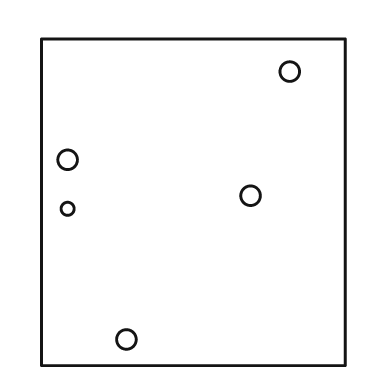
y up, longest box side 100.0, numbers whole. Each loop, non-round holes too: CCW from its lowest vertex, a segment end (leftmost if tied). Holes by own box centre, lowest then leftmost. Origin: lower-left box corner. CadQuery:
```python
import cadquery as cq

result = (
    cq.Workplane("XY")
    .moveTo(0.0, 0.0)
    .lineTo(93.0, 0.0)
    .lineTo(93.0, 100.0)
    .lineTo(0.0, 100.0)
    .close()
    .moveTo(26.0, 8.0)
    .circle(3.0)
    .moveTo(8.0, 48.0)
    .circle(2.0)
    .moveTo(64.0, 52.0)
    .circle(3.0)
    .moveTo(8.0, 63.0)
    .circle(3.0)
    .moveTo(76.0, 90.0)
    .circle(3.0)
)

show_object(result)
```